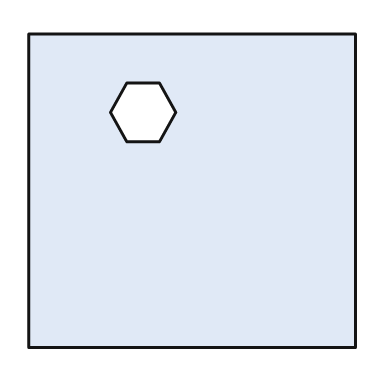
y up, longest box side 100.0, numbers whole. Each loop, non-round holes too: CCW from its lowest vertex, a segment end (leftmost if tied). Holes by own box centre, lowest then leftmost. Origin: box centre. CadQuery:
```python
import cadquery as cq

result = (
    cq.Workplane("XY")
    .moveTo(-50.0, -48.0)
    .lineTo(50.0, -48.0)
    .lineTo(50.0, 48.0)
    .lineTo(-50.0, 48.0)
    .close()
    .moveTo(-20.0, 15.0)
    .lineTo(-10.0, 15.0)
    .lineTo(-5.0, 24.0)
    .lineTo(-10.0, 33.0)
    .lineTo(-20.0, 33.0)
    .lineTo(-25.0, 24.0)
    .close()
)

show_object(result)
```